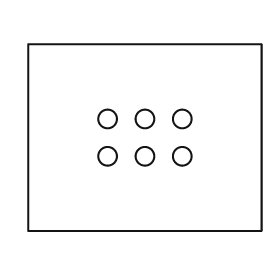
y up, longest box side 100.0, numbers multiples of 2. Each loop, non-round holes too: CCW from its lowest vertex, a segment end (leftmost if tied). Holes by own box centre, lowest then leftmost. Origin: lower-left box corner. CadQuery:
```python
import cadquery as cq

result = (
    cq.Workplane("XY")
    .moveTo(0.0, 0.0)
    .lineTo(100.0, 0.0)
    .lineTo(100.0, 80.0)
    .lineTo(0.0, 80.0)
    .close()
    .moveTo(34.0, 32.0)
    .circle(4.0)
    .moveTo(50.0, 32.0)
    .circle(4.0)
    .moveTo(66.0, 32.0)
    .circle(4.0)
    .moveTo(34.0, 48.0)
    .circle(4.0)
    .moveTo(50.0, 48.0)
    .circle(4.0)
    .moveTo(66.0, 48.0)
    .circle(4.0)
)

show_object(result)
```